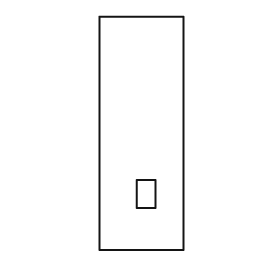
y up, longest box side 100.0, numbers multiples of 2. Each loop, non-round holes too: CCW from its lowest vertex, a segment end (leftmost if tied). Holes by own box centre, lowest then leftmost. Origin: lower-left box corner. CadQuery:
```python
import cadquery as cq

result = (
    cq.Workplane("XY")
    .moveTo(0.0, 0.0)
    .lineTo(36.0, 0.0)
    .lineTo(36.0, 100.0)
    .lineTo(0.0, 100.0)
    .close()
    .moveTo(16.0, 18.0)
    .lineTo(24.0, 18.0)
    .lineTo(24.0, 30.0)
    .lineTo(16.0, 30.0)
    .close()
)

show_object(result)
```